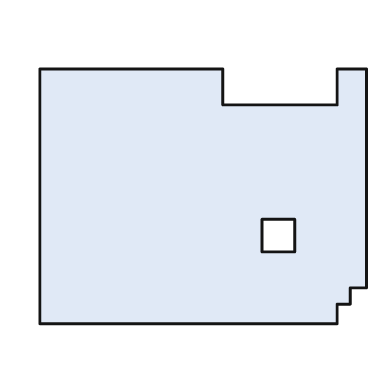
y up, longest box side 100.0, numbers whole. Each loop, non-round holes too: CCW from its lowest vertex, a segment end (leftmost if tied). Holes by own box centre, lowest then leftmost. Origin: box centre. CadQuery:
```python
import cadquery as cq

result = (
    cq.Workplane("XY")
    .moveTo(-50.0, -39.0)
    .lineTo(41.0, -39.0)
    .lineTo(41.0, -33.0)
    .lineTo(45.0, -33.0)
    .lineTo(45.0, -28.0)
    .lineTo(50.0, -28.0)
    .lineTo(50.0, 39.0)
    .lineTo(41.0, 39.0)
    .lineTo(41.0, 28.0)
    .lineTo(6.0, 28.0)
    .lineTo(6.0, 39.0)
    .lineTo(-50.0, 39.0)
    .close()
    .moveTo(18.0, -17.0)
    .lineTo(28.0, -17.0)
    .lineTo(28.0, -7.0)
    .lineTo(18.0, -7.0)
    .close()
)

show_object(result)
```